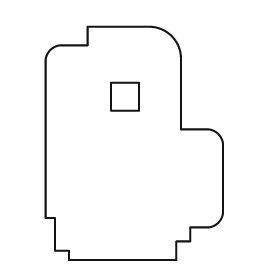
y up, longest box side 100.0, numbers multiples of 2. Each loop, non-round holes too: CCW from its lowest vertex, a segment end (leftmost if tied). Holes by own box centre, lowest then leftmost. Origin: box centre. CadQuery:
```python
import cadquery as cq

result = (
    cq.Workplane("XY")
    .moveTo(-28.0, -50.0)
    .lineTo(18.0, -50.0)
    .lineTo(18.0, -42.0)
    .lineTo(24.0, -42.0)
    .lineTo(24.0, -36.0)
    .lineTo(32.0, -36.0)
    .threePointArc((36.0, -34.0), (38.0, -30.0))
    .lineTo(38.0, 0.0)
    .threePointArc((36.0, 4.0), (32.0, 6.0))
    .lineTo(20.0, 6.0)
    .lineTo(20.0, 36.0)
    .threePointArc((16.0, 46.0), (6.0, 50.0))
    .lineTo(-20.0, 50.0)
    .lineTo(-20.0, 42.0)
    .lineTo(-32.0, 42.0)
    .threePointArc((-36.0, 40.0), (-38.0, 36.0))
    .lineTo(-38.0, -32.0)
    .lineTo(-34.0, -32.0)
    .lineTo(-34.0, -46.0)
    .lineTo(-28.0, -46.0)
    .close()
    .moveTo(-10.0, 14.0)
    .lineTo(2.0, 14.0)
    .lineTo(2.0, 26.0)
    .lineTo(-10.0, 26.0)
    .close()
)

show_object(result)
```